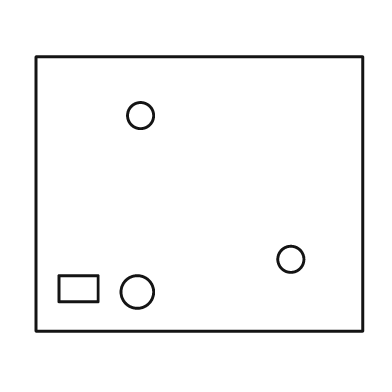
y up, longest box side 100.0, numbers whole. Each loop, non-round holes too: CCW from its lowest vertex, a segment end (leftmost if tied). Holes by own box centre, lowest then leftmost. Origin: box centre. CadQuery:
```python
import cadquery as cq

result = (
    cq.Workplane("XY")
    .moveTo(-50.0, -42.0)
    .lineTo(50.0, -42.0)
    .lineTo(50.0, 42.0)
    .lineTo(-50.0, 42.0)
    .close()
    .moveTo(-19.0, -30.0)
    .circle(5.0)
    .moveTo(-43.0, -33.0)
    .lineTo(-31.0, -33.0)
    .lineTo(-31.0, -25.0)
    .lineTo(-43.0, -25.0)
    .close()
    .moveTo(28.0, -20.0)
    .circle(4.0)
    .moveTo(-18.0, 24.0)
    .circle(4.0)
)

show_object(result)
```